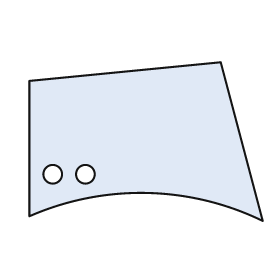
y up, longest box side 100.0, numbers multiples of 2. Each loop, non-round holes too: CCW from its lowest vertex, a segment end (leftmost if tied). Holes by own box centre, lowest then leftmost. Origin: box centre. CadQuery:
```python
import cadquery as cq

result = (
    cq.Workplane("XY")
    .moveTo(50.0, -34.0)
    .lineTo(32.0, 34.0)
    .lineTo(-50.0, 26.0)
    .lineTo(-50.0, -32.0)
    .threePointArc((0.0, -22.0), (50.0, -34.0))
    .close()
    .moveTo(-40.0, -14.0)
    .circle(4.0)
    .moveTo(-26.0, -14.0)
    .circle(4.0)
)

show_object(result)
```